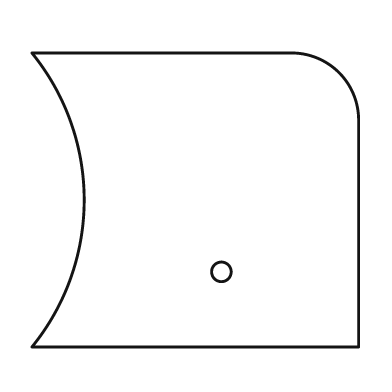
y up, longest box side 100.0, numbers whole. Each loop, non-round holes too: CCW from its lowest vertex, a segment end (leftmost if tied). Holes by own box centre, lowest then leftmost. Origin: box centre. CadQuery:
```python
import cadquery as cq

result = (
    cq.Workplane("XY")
    .moveTo(-50.0, -45.0)
    .lineTo(50.0, -45.0)
    .lineTo(50.0, 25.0)
    .threePointArc((44.0, 39.0), (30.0, 45.0))
    .lineTo(-50.0, 45.0)
    .threePointArc((-34.0, 0.0), (-50.0, -45.0))
    .close()
    .moveTo(8.0, -22.0)
    .circle(3.0)
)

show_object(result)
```